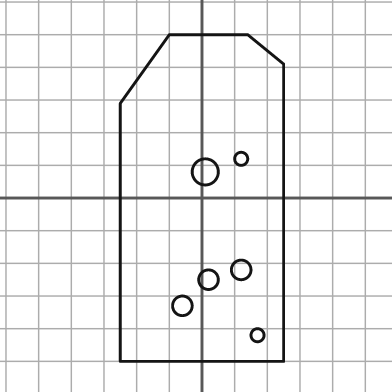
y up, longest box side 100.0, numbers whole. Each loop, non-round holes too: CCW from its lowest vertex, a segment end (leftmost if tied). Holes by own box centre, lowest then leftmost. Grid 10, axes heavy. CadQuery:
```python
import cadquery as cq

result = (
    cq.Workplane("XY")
    .moveTo(-25.0, -50.0)
    .lineTo(25.0, -50.0)
    .lineTo(25.0, 41.0)
    .lineTo(14.0, 50.0)
    .lineTo(-10.0, 50.0)
    .lineTo(-25.0, 29.0)
    .close()
    .moveTo(17.0, -42.0)
    .circle(2.0)
    .moveTo(-6.0, -33.0)
    .circle(3.0)
    .moveTo(2.0, -25.0)
    .circle(3.0)
    .moveTo(12.0, -22.0)
    .circle(3.0)
    .moveTo(1.0, 8.0)
    .circle(4.0)
    .moveTo(12.0, 12.0)
    .circle(2.0)
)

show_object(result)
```